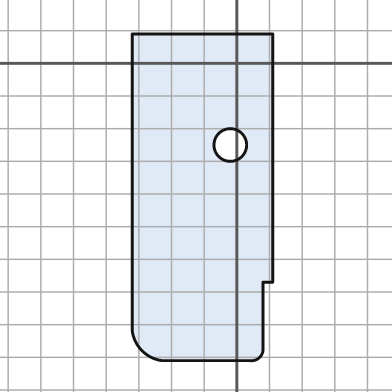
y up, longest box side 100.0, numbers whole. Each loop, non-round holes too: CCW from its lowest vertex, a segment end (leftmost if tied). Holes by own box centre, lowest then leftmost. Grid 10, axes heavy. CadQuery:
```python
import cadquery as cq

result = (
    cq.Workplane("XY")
    .moveTo(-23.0, -91.0)
    .lineTo(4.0, -91.0)
    .threePointArc((7.0, -90.0), (8.0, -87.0))
    .lineTo(8.0, -67.0)
    .lineTo(11.0, -67.0)
    .lineTo(11.0, 9.0)
    .lineTo(-32.0, 9.0)
    .lineTo(-32.0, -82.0)
    .threePointArc((-29.0, -88.0), (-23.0, -91.0))
    .close()
    .moveTo(-2.0, -25.0)
    .circle(5.0)
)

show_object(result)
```